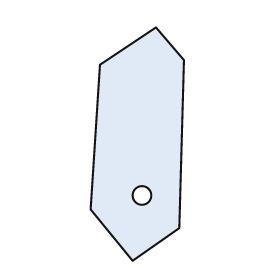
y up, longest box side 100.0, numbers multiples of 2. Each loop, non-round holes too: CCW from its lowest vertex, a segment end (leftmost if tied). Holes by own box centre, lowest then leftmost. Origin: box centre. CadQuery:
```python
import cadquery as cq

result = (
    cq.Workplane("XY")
    .moveTo(-2.0, -50.0)
    .lineTo(18.0, -36.0)
    .lineTo(20.0, 36.0)
    .lineTo(8.0, 50.0)
    .lineTo(-16.0, 34.0)
    .lineTo(-20.0, -28.0)
    .close()
    .moveTo(2.0, -22.0)
    .circle(4.0)
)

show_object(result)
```